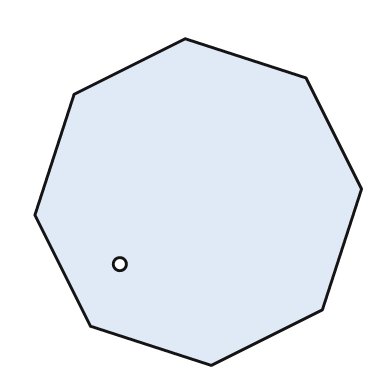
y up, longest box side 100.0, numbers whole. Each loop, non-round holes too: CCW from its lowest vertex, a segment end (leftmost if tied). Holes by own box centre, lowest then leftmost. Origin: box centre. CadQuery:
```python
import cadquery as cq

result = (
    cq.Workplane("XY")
    .moveTo(4.0, -50.0)
    .lineTo(38.0, -33.0)
    .lineTo(50.0, 4.0)
    .lineTo(33.0, 38.0)
    .lineTo(-4.0, 50.0)
    .lineTo(-38.0, 33.0)
    .lineTo(-50.0, -4.0)
    .lineTo(-33.0, -38.0)
    .close()
    .moveTo(-24.0, -19.0)
    .circle(2.0)
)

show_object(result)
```